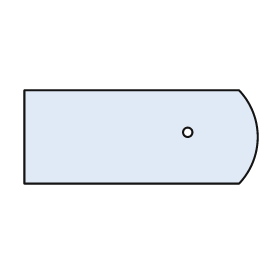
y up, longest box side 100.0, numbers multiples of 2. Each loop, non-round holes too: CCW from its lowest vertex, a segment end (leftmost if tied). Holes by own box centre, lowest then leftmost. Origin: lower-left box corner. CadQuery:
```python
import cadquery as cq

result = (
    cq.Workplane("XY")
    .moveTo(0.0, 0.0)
    .lineTo(92.0, 0.0)
    .threePointArc((100.0, 20.0), (92.0, 40.0))
    .lineTo(0.0, 40.0)
    .close()
    .moveTo(70.0, 22.0)
    .circle(2.0)
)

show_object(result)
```